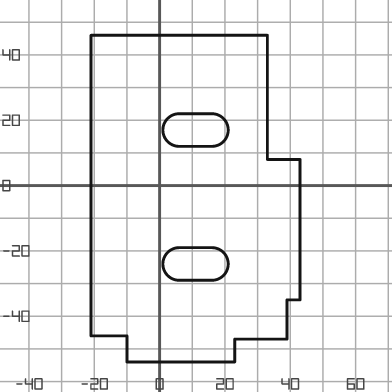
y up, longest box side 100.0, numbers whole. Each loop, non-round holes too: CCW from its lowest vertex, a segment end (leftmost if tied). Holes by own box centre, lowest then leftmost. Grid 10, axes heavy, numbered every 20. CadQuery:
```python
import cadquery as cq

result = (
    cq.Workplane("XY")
    .moveTo(-10.0, -54.0)
    .lineTo(23.0, -54.0)
    .lineTo(23.0, -47.0)
    .lineTo(39.0, -47.0)
    .lineTo(39.0, -35.0)
    .lineTo(43.0, -35.0)
    .lineTo(43.0, 8.0)
    .lineTo(33.0, 8.0)
    .lineTo(33.0, 46.0)
    .lineTo(-21.0, 46.0)
    .lineTo(-21.0, -46.0)
    .lineTo(-10.0, -46.0)
    .close()
    .moveTo(6.0, -29.0)
    .lineTo(16.0, -29.0)
    .threePointArc((21.0, -24.0), (16.0, -19.0))
    .lineTo(6.0, -19.0)
    .threePointArc((1.0, -24.0), (6.0, -29.0))
    .close()
    .moveTo(6.0, 12.0)
    .lineTo(16.0, 12.0)
    .threePointArc((21.0, 17.0), (16.0, 22.0))
    .lineTo(6.0, 22.0)
    .threePointArc((1.0, 17.0), (6.0, 12.0))
    .close()
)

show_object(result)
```